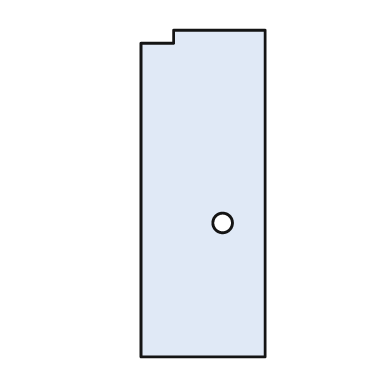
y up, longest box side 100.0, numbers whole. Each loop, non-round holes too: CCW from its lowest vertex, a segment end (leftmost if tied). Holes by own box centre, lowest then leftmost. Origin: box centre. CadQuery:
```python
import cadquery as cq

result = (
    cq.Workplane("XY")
    .moveTo(-19.0, -50.0)
    .lineTo(19.0, -50.0)
    .lineTo(19.0, 50.0)
    .lineTo(-9.0, 50.0)
    .lineTo(-9.0, 46.0)
    .lineTo(-19.0, 46.0)
    .close()
    .moveTo(6.0, -9.0)
    .circle(3.0)
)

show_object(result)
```